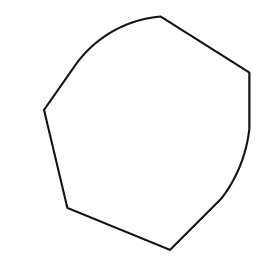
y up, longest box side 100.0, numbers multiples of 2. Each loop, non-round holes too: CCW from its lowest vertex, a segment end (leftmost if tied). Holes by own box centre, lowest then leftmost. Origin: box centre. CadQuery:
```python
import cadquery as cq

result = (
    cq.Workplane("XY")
    .moveTo(10.0, -50.0)
    .lineTo(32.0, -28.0)
    .threePointArc((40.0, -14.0), (44.0, 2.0))
    .lineTo(44.0, 26.0)
    .lineTo(6.0, 50.0)
    .threePointArc((-14.0, 44.0), (-30.0, 30.0))
    .lineTo(-44.0, 10.0)
    .lineTo(-34.0, -32.0)
    .close()
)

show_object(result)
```